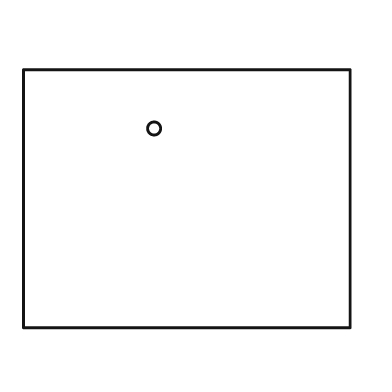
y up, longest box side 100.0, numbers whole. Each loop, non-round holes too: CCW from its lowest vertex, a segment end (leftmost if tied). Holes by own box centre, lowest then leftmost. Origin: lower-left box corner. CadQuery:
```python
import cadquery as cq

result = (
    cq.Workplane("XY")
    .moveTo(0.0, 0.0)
    .lineTo(100.0, 0.0)
    .lineTo(100.0, 79.0)
    .lineTo(0.0, 79.0)
    .close()
    .moveTo(40.0, 61.0)
    .circle(2.0)
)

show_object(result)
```